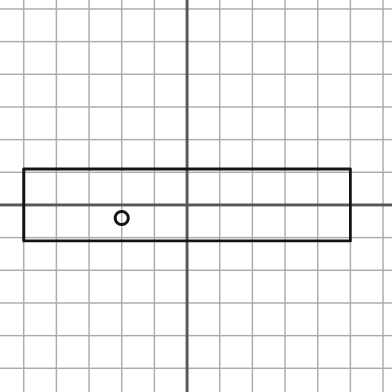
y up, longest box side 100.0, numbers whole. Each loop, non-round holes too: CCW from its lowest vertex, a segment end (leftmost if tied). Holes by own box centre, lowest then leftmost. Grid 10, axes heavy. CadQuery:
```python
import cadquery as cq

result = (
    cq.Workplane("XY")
    .moveTo(-50.0, -11.0)
    .lineTo(50.0, -11.0)
    .lineTo(50.0, 11.0)
    .lineTo(-50.0, 11.0)
    .close()
    .moveTo(-20.0, -4.0)
    .circle(2.0)
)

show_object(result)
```